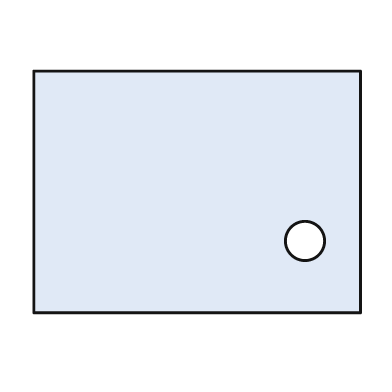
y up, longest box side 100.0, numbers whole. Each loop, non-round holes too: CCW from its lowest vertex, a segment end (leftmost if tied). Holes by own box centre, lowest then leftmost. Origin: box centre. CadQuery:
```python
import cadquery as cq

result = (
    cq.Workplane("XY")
    .moveTo(-50.0, -37.0)
    .lineTo(50.0, -37.0)
    .lineTo(50.0, 37.0)
    .lineTo(-50.0, 37.0)
    .close()
    .moveTo(33.0, -15.0)
    .circle(6.0)
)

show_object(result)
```